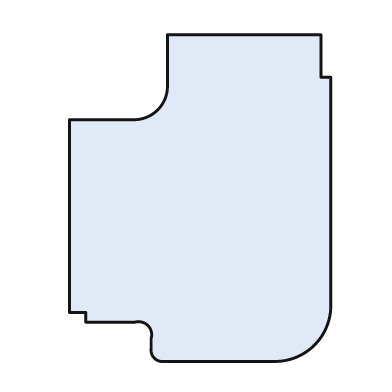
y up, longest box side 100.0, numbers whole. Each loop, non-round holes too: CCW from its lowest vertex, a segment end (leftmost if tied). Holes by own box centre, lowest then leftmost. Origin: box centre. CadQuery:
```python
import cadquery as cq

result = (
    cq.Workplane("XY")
    .moveTo(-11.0, -50.0)
    .lineTo(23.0, -50.0)
    .threePointArc((35.0, -45.0), (40.0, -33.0))
    .lineTo(40.0, 37.0)
    .lineTo(37.0, 37.0)
    .lineTo(37.0, 50.0)
    .lineTo(-10.0, 50.0)
    .lineTo(-10.0, 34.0)
    .threePointArc((-13.0, 27.0), (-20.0, 24.0))
    .lineTo(-40.0, 24.0)
    .lineTo(-40.0, -35.0)
    .lineTo(-35.0, -35.0)
    .lineTo(-35.0, -38.0)
    .lineTo(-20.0, -38.0)
    .threePointArc((-16.0, -39.0), (-15.0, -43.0))
    .lineTo(-15.0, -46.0)
    .threePointArc((-14.0, -49.0), (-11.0, -50.0))
    .close()
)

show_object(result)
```